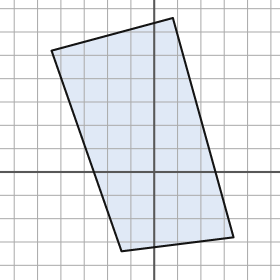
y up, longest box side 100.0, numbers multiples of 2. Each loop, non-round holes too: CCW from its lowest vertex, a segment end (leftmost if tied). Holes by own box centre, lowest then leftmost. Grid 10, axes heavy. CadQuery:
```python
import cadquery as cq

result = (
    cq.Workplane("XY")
    .moveTo(-14.0, -34.0)
    .lineTo(34.0, -28.0)
    .lineTo(8.0, 66.0)
    .lineTo(-44.0, 52.0)
    .close()
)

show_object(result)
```